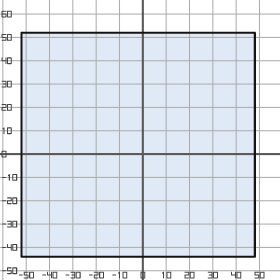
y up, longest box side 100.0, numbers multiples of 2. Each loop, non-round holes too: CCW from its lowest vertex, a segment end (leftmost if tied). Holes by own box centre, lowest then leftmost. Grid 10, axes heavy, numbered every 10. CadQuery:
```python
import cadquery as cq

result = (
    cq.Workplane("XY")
    .moveTo(-52.0, -44.0)
    .lineTo(48.0, -44.0)
    .lineTo(48.0, 52.0)
    .lineTo(-52.0, 52.0)
    .close()
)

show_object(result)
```